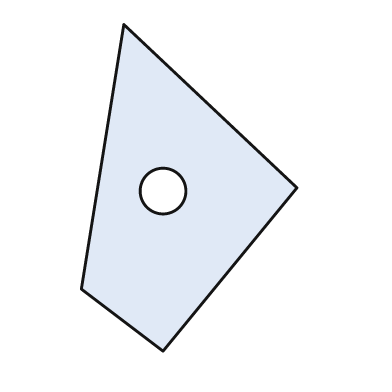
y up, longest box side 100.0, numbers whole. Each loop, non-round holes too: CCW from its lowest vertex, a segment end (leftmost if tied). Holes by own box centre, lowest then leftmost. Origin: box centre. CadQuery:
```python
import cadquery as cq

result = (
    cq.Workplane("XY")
    .moveTo(-8.0, -50.0)
    .lineTo(33.0, 0.0)
    .lineTo(-20.0, 50.0)
    .lineTo(-33.0, -31.0)
    .close()
    .moveTo(-8.0, -1.0)
    .circle(7.0)
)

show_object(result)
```